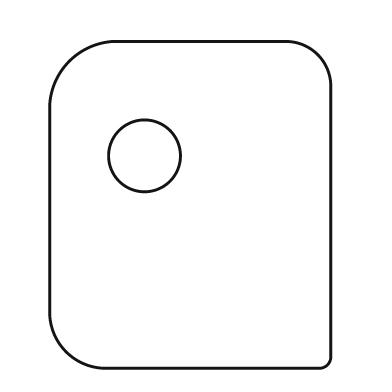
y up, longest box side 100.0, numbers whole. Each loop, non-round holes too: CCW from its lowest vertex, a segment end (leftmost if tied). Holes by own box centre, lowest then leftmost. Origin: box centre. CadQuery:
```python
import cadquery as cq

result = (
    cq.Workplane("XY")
    .moveTo(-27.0, -50.0)
    .lineTo(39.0, -50.0)
    .threePointArc((42.0, -49.0), (43.0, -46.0))
    .lineTo(43.0, 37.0)
    .threePointArc((39.0, 46.0), (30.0, 50.0))
    .lineTo(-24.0, 50.0)
    .threePointArc((-37.0, 44.0), (-43.0, 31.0))
    .lineTo(-43.0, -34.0)
    .threePointArc((-38.0, -45.0), (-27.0, -50.0))
    .close()
    .moveTo(-14.0, 15.0)
    .circle(11.0)
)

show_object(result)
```